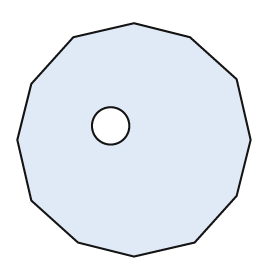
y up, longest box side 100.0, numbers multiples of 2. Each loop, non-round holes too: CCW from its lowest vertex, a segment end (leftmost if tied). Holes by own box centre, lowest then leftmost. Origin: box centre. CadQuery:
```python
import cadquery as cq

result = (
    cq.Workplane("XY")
    .moveTo(0.0, -50.0)
    .lineTo(26.0, -44.0)
    .lineTo(44.0, -24.0)
    .lineTo(50.0, 0.0)
    .lineTo(44.0, 26.0)
    .lineTo(24.0, 44.0)
    .lineTo(0.0, 50.0)
    .lineTo(-26.0, 44.0)
    .lineTo(-44.0, 24.0)
    .lineTo(-50.0, 0.0)
    .lineTo(-44.0, -26.0)
    .lineTo(-24.0, -44.0)
    .close()
    .moveTo(-10.0, 6.0)
    .circle(8.0)
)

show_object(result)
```